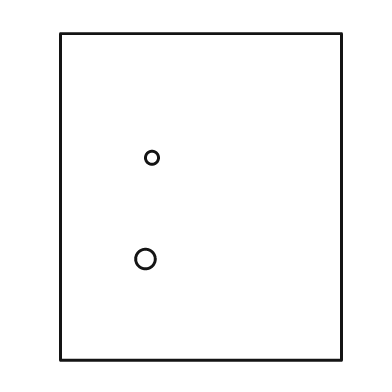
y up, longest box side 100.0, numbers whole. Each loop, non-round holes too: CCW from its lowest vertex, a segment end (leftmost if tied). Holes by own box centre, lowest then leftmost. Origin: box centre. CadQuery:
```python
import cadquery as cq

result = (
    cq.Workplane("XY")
    .moveTo(-43.0, -50.0)
    .lineTo(43.0, -50.0)
    .lineTo(43.0, 50.0)
    .lineTo(-43.0, 50.0)
    .close()
    .moveTo(-17.0, -19.0)
    .circle(3.0)
    .moveTo(-15.0, 12.0)
    .circle(2.0)
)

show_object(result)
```